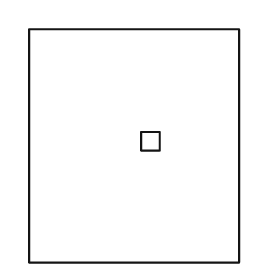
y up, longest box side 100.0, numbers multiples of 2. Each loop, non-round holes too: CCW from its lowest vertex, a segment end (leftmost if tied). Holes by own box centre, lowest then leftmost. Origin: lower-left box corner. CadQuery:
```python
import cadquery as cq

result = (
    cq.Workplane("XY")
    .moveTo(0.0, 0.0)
    .lineTo(90.0, 0.0)
    .lineTo(90.0, 100.0)
    .lineTo(0.0, 100.0)
    .close()
    .moveTo(48.0, 48.0)
    .lineTo(56.0, 48.0)
    .lineTo(56.0, 56.0)
    .lineTo(48.0, 56.0)
    .close()
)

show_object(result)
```